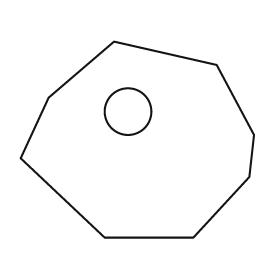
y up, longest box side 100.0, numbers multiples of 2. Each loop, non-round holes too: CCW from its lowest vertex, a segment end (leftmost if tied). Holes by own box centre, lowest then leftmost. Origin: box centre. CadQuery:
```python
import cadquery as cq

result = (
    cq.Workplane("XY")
    .moveTo(-14.0, -42.0)
    .lineTo(24.0, -42.0)
    .lineTo(48.0, -16.0)
    .lineTo(50.0, 2.0)
    .lineTo(34.0, 32.0)
    .lineTo(-10.0, 42.0)
    .lineTo(-38.0, 18.0)
    .lineTo(-50.0, -8.0)
    .close()
    .moveTo(-4.0, 12.0)
    .circle(10.0)
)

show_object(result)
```